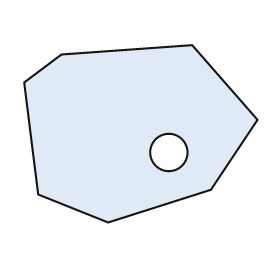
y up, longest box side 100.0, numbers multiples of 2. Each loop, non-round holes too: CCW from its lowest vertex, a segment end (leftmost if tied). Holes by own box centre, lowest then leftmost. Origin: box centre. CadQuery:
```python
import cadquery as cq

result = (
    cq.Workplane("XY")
    .moveTo(-14.0, -38.0)
    .lineTo(30.0, -24.0)
    .lineTo(50.0, 6.0)
    .lineTo(22.0, 38.0)
    .lineTo(-34.0, 34.0)
    .lineTo(-50.0, 22.0)
    .lineTo(-44.0, -26.0)
    .close()
    .moveTo(12.0, -8.0)
    .circle(8.0)
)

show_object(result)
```